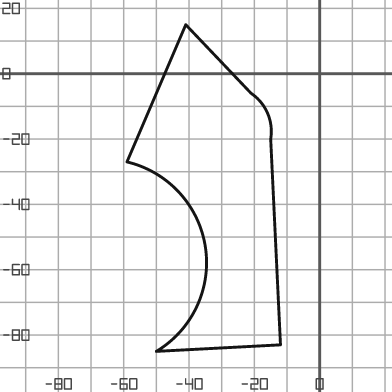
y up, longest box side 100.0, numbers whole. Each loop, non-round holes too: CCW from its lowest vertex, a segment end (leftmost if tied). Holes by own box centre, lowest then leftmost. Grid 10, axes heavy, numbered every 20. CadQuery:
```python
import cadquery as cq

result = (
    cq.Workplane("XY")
    .moveTo(-50.0, -85.0)
    .lineTo(-12.0, -83.0)
    .lineTo(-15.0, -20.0)
    .threePointArc((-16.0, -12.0), (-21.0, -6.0))
    .lineTo(-41.0, 15.0)
    .lineTo(-59.0, -27.0)
    .threePointArc((-35.0, -53.0), (-50.0, -85.0))
    .close()
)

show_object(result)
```